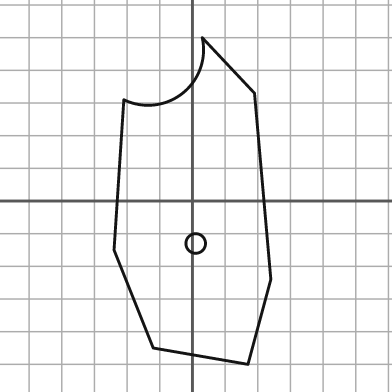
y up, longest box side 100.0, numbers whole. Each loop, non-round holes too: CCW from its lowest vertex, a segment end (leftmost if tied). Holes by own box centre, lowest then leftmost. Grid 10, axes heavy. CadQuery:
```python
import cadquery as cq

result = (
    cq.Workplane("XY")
    .moveTo(17.0, -50.0)
    .lineTo(24.0, -24.0)
    .lineTo(19.0, 33.0)
    .lineTo(3.0, 50.0)
    .threePointArc((-3.0, 33.0), (-21.0, 31.0))
    .lineTo(-24.0, -15.0)
    .lineTo(-12.0, -45.0)
    .close()
    .moveTo(1.0, -13.0)
    .circle(3.0)
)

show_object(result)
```